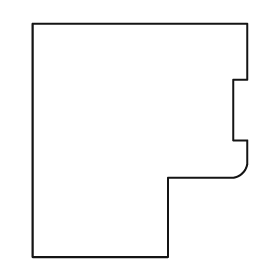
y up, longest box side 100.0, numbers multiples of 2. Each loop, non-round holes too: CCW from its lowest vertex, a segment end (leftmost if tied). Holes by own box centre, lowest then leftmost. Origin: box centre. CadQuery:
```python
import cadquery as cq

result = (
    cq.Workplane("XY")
    .moveTo(-46.0, -50.0)
    .lineTo(12.0, -50.0)
    .lineTo(12.0, -16.0)
    .lineTo(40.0, -16.0)
    .threePointArc((44.0, -14.0), (46.0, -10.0))
    .lineTo(46.0, 0.0)
    .lineTo(40.0, 0.0)
    .lineTo(40.0, 26.0)
    .lineTo(46.0, 26.0)
    .lineTo(46.0, 50.0)
    .lineTo(-46.0, 50.0)
    .close()
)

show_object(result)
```